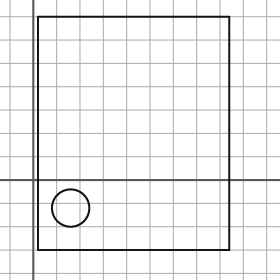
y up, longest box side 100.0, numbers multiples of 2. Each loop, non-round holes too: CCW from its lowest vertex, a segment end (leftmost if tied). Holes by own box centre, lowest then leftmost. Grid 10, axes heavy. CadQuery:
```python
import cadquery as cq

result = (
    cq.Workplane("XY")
    .moveTo(2.0, -30.0)
    .lineTo(84.0, -30.0)
    .lineTo(84.0, 70.0)
    .lineTo(2.0, 70.0)
    .close()
    .moveTo(16.0, -12.0)
    .circle(8.0)
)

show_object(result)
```